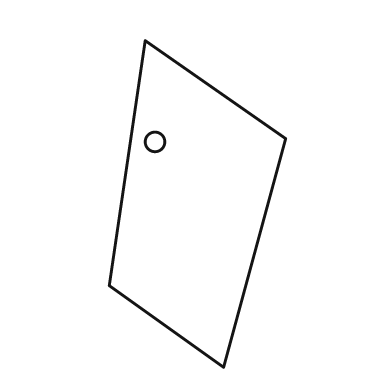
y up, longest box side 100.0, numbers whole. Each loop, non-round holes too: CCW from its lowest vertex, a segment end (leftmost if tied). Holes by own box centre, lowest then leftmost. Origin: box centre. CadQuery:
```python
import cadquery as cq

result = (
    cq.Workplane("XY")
    .moveTo(8.0, -50.0)
    .lineTo(27.0, 20.0)
    .lineTo(-16.0, 50.0)
    .lineTo(-27.0, -25.0)
    .close()
    .moveTo(-13.0, 19.0)
    .circle(3.0)
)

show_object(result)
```